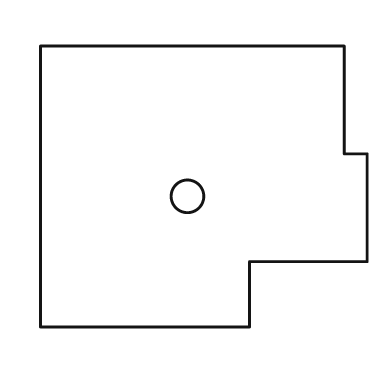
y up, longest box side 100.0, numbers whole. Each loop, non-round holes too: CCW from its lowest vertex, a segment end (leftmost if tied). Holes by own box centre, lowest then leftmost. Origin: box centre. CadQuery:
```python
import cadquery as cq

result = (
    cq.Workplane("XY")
    .moveTo(-50.0, -43.0)
    .lineTo(14.0, -43.0)
    .lineTo(14.0, -23.0)
    .lineTo(50.0, -23.0)
    .lineTo(50.0, 10.0)
    .lineTo(43.0, 10.0)
    .lineTo(43.0, 43.0)
    .lineTo(-50.0, 43.0)
    .close()
    .moveTo(-5.0, -3.0)
    .circle(5.0)
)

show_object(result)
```